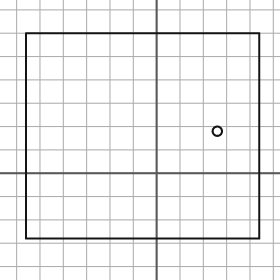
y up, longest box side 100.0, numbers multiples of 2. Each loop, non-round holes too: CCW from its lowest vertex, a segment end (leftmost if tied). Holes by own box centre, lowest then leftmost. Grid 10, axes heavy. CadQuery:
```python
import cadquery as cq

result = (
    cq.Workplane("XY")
    .moveTo(-56.0, -28.0)
    .lineTo(44.0, -28.0)
    .lineTo(44.0, 60.0)
    .lineTo(-56.0, 60.0)
    .close()
    .moveTo(26.0, 18.0)
    .circle(2.0)
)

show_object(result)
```